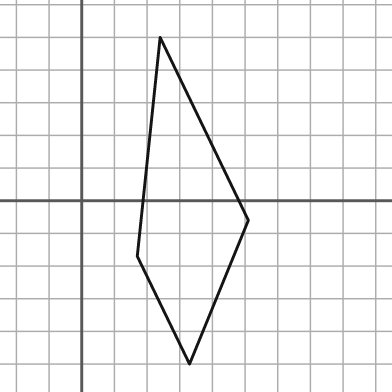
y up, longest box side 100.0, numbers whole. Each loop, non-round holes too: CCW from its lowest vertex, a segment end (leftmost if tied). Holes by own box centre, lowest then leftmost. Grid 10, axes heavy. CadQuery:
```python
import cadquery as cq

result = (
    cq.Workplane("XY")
    .moveTo(33.0, -50.0)
    .lineTo(51.0, -6.0)
    .lineTo(24.0, 50.0)
    .lineTo(17.0, -17.0)
    .close()
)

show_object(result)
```